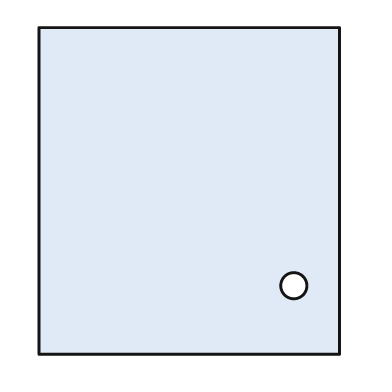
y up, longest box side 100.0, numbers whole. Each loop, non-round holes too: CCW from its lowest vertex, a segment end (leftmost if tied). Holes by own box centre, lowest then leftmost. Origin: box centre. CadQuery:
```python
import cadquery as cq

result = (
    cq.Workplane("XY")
    .moveTo(-46.0, -50.0)
    .lineTo(46.0, -50.0)
    .lineTo(46.0, 50.0)
    .lineTo(-46.0, 50.0)
    .close()
    .moveTo(32.0, -29.0)
    .circle(4.0)
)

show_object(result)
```